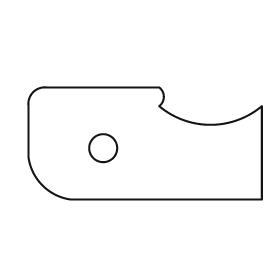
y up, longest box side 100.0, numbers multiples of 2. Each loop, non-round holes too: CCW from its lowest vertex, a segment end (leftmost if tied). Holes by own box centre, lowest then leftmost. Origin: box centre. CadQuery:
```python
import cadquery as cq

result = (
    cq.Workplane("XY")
    .moveTo(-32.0, -24.0)
    .lineTo(50.0, -24.0)
    .lineTo(50.0, 16.0)
    .threePointArc((28.0, 8.0), (6.0, 16.0))
    .threePointArc((8.0, 20.0), (6.0, 24.0))
    .lineTo(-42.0, 24.0)
    .threePointArc((-48.0, 22.0), (-50.0, 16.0))
    .lineTo(-50.0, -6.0)
    .threePointArc((-44.0, -18.0), (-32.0, -24.0))
    .close()
    .moveTo(-18.0, -2.0)
    .circle(6.0)
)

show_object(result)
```